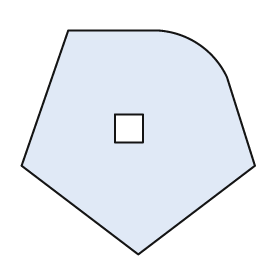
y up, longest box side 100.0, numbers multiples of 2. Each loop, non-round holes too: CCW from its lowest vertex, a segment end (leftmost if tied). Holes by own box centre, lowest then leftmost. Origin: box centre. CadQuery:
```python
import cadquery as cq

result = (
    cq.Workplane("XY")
    .moveTo(0.0, -48.0)
    .lineTo(50.0, -10.0)
    .lineTo(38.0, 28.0)
    .threePointArc((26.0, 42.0), (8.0, 48.0))
    .lineTo(-30.0, 48.0)
    .lineTo(-50.0, -10.0)
    .close()
    .moveTo(-10.0, 0.0)
    .lineTo(2.0, 0.0)
    .lineTo(2.0, 12.0)
    .lineTo(-10.0, 12.0)
    .close()
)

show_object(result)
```